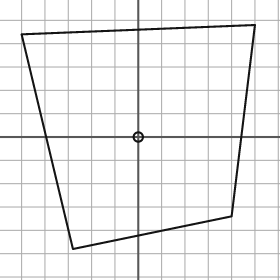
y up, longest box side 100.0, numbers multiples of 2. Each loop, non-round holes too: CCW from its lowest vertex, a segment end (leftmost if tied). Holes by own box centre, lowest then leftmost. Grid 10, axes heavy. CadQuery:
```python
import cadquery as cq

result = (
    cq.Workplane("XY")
    .moveTo(-28.0, -48.0)
    .lineTo(40.0, -34.0)
    .lineTo(50.0, 48.0)
    .lineTo(-50.0, 44.0)
    .close()
    .moveTo(0.0, 0.0)
    .circle(2.0)
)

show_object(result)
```